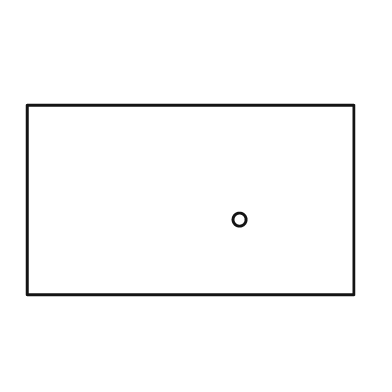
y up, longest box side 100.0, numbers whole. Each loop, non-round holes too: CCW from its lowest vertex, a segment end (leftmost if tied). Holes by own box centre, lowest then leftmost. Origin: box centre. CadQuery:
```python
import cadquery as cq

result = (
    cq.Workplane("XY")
    .moveTo(-50.0, -29.0)
    .lineTo(50.0, -29.0)
    .lineTo(50.0, 29.0)
    .lineTo(-50.0, 29.0)
    .close()
    .moveTo(15.0, -6.0)
    .circle(2.0)
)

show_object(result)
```